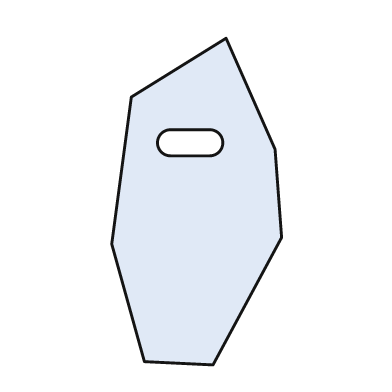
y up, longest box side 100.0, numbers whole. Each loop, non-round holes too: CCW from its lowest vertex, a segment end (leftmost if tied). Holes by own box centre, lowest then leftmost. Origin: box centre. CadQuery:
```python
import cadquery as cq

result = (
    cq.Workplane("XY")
    .moveTo(5.0, -50.0)
    .lineTo(26.0, -11.0)
    .lineTo(24.0, 16.0)
    .lineTo(9.0, 50.0)
    .lineTo(-20.0, 32.0)
    .lineTo(-26.0, -13.0)
    .lineTo(-16.0, -49.0)
    .close()
    .moveTo(-8.0, 14.0)
    .lineTo(4.0, 14.0)
    .threePointArc((8.0, 18.0), (4.0, 22.0))
    .lineTo(-8.0, 22.0)
    .threePointArc((-12.0, 18.0), (-8.0, 14.0))
    .close()
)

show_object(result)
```